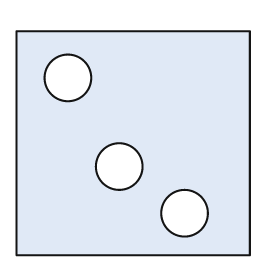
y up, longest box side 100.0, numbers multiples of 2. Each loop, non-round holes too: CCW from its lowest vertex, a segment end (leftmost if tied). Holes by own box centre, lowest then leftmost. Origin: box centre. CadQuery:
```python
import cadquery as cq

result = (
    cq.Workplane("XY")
    .moveTo(-50.0, -48.0)
    .lineTo(50.0, -48.0)
    .lineTo(50.0, 48.0)
    .lineTo(-50.0, 48.0)
    .close()
    .moveTo(22.0, -30.0)
    .circle(10.0)
    .moveTo(-6.0, -10.0)
    .circle(10.0)
    .moveTo(-28.0, 28.0)
    .circle(10.0)
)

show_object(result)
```